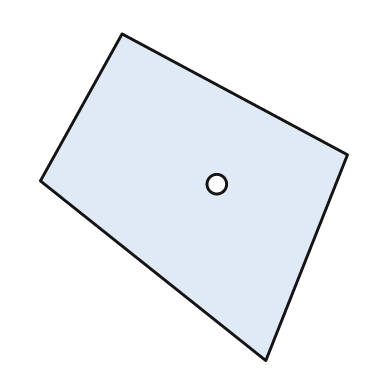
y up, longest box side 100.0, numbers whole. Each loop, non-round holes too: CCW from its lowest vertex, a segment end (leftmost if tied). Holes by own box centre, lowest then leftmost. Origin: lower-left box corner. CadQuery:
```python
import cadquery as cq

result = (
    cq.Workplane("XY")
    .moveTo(69.0, 0.0)
    .lineTo(94.0, 63.0)
    .lineTo(25.0, 100.0)
    .lineTo(0.0, 55.0)
    .close()
    .moveTo(54.0, 54.0)
    .circle(3.0)
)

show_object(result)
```